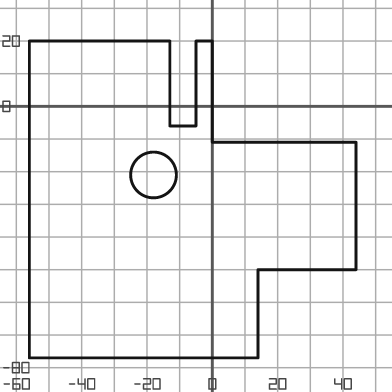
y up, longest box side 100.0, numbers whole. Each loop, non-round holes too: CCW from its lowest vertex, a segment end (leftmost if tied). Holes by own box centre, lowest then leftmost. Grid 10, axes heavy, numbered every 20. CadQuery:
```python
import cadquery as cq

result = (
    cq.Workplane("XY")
    .moveTo(-56.0, -77.0)
    .lineTo(14.0, -77.0)
    .lineTo(14.0, -50.0)
    .lineTo(44.0, -50.0)
    .lineTo(44.0, -11.0)
    .lineTo(0.0, -11.0)
    .lineTo(0.0, 20.0)
    .lineTo(-5.0, 20.0)
    .lineTo(-5.0, -6.0)
    .lineTo(-13.0, -6.0)
    .lineTo(-13.0, 20.0)
    .lineTo(-56.0, 20.0)
    .close()
    .moveTo(-18.0, -21.0)
    .circle(7.0)
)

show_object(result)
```